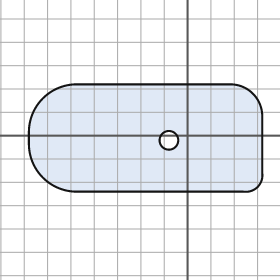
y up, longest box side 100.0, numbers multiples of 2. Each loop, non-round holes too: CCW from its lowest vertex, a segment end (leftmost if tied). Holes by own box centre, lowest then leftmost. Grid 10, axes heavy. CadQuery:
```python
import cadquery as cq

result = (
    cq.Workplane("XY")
    .moveTo(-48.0, -24.0)
    .lineTo(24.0, -24.0)
    .threePointArc((30.0, -22.0), (32.0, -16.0))
    .lineTo(32.0, 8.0)
    .threePointArc((28.0, 18.0), (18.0, 22.0))
    .lineTo(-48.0, 22.0)
    .threePointArc((-62.0, 16.0), (-68.0, 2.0))
    .lineTo(-68.0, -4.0)
    .threePointArc((-62.0, -18.0), (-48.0, -24.0))
    .close()
    .moveTo(-8.0, -2.0)
    .circle(4.0)
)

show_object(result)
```